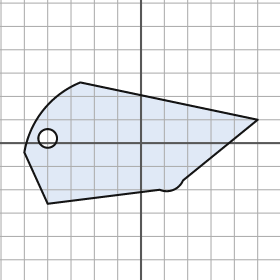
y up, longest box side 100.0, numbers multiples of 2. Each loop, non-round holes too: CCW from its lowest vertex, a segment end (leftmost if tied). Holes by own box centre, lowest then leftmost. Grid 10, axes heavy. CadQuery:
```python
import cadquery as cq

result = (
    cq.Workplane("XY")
    .moveTo(-40.0, -26.0)
    .lineTo(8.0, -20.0)
    .threePointArc((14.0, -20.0), (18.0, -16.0))
    .lineTo(50.0, 10.0)
    .lineTo(-26.0, 26.0)
    .threePointArc((-42.0, 14.0), (-50.0, -4.0))
    .close()
    .moveTo(-40.0, 2.0)
    .circle(4.0)
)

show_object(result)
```